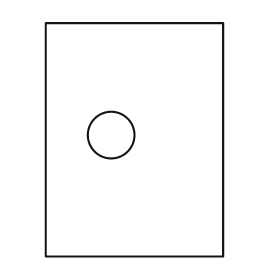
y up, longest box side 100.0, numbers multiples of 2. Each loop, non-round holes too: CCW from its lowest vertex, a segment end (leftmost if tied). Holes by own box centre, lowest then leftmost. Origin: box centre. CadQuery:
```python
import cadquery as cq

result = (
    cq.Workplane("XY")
    .moveTo(-38.0, -50.0)
    .lineTo(38.0, -50.0)
    .lineTo(38.0, 50.0)
    .lineTo(-38.0, 50.0)
    .close()
    .moveTo(-10.0, 2.0)
    .circle(10.0)
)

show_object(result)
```